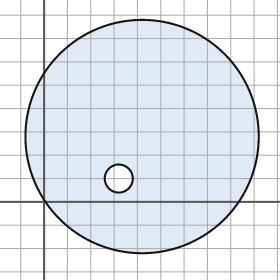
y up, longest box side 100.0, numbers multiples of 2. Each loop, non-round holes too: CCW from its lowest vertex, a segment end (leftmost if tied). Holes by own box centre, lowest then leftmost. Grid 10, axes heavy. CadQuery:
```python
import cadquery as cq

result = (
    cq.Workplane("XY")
    .moveTo(42.0, 28.0)
    .circle(50.0)
    .moveTo(32.0, 10.0)
    .circle(6.0)
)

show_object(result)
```